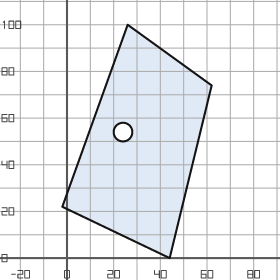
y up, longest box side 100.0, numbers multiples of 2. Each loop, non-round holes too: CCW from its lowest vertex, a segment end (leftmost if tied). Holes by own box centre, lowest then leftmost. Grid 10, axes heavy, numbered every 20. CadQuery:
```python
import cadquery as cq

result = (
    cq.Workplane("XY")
    .moveTo(44.0, 0.0)
    .lineTo(62.0, 74.0)
    .lineTo(26.0, 100.0)
    .lineTo(-2.0, 22.0)
    .close()
    .moveTo(24.0, 54.0)
    .circle(4.0)
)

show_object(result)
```